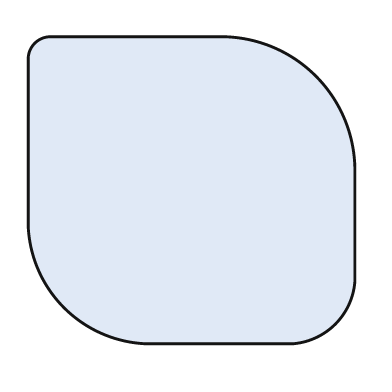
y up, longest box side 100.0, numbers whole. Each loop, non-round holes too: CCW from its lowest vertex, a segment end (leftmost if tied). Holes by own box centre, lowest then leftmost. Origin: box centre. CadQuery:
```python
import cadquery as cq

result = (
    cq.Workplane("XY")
    .moveTo(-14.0, -47.0)
    .lineTo(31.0, -47.0)
    .threePointArc((44.0, -41.0), (50.0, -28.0))
    .lineTo(50.0, 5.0)
    .threePointArc((38.0, 35.0), (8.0, 47.0))
    .lineTo(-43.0, 47.0)
    .threePointArc((-48.0, 45.0), (-50.0, 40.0))
    .lineTo(-50.0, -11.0)
    .threePointArc((-39.0, -36.0), (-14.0, -47.0))
    .close()
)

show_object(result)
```